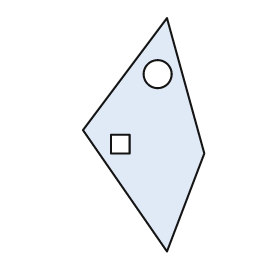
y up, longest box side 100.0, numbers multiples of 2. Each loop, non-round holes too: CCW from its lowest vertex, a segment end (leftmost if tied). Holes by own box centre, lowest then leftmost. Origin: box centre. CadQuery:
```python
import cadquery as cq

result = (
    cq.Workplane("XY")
    .moveTo(10.0, -50.0)
    .lineTo(26.0, -8.0)
    .lineTo(10.0, 50.0)
    .lineTo(-26.0, 2.0)
    .close()
    .moveTo(-14.0, -8.0)
    .lineTo(-6.0, -8.0)
    .lineTo(-6.0, 0.0)
    .lineTo(-14.0, 0.0)
    .close()
    .moveTo(6.0, 26.0)
    .circle(6.0)
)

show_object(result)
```